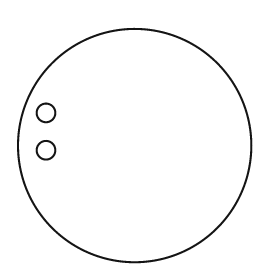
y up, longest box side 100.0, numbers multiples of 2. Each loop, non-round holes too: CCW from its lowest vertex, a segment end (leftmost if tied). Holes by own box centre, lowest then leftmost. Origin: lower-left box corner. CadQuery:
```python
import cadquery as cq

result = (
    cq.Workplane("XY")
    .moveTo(50.0, 50.0)
    .circle(50.0)
    .moveTo(12.0, 48.0)
    .circle(4.0)
    .moveTo(12.0, 64.0)
    .circle(4.0)
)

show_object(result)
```